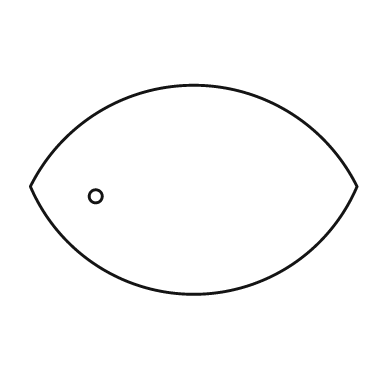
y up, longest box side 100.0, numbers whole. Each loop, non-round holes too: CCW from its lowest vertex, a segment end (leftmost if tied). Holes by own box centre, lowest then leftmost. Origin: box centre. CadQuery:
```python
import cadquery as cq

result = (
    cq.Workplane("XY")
    .moveTo(-50.0, 1.0)
    .threePointArc((0.0, -32.0), (50.0, 1.0))
    .threePointArc((0.0, 32.0), (-50.0, 1.0))
    .close()
    .moveTo(-30.0, -2.0)
    .circle(2.0)
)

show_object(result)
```